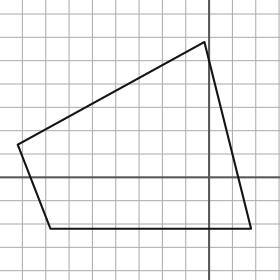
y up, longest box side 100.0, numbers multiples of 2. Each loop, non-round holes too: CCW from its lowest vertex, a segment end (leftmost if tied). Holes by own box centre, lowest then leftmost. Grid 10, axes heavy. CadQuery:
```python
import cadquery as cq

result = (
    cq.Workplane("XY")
    .moveTo(-68.0, -22.0)
    .lineTo(18.0, -22.0)
    .lineTo(-2.0, 58.0)
    .lineTo(-82.0, 14.0)
    .close()
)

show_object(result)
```